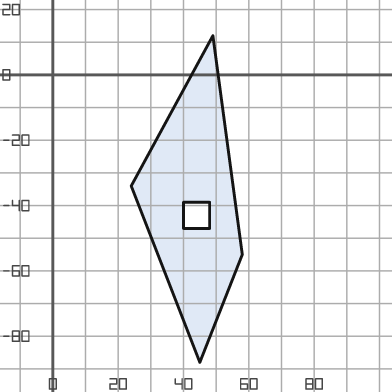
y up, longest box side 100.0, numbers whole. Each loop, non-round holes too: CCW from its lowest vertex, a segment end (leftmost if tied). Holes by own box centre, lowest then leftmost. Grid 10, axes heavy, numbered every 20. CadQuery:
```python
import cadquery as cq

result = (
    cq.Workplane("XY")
    .moveTo(45.0, -88.0)
    .lineTo(58.0, -55.0)
    .lineTo(49.0, 12.0)
    .lineTo(24.0, -34.0)
    .close()
    .moveTo(40.0, -47.0)
    .lineTo(48.0, -47.0)
    .lineTo(48.0, -39.0)
    .lineTo(40.0, -39.0)
    .close()
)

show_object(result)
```